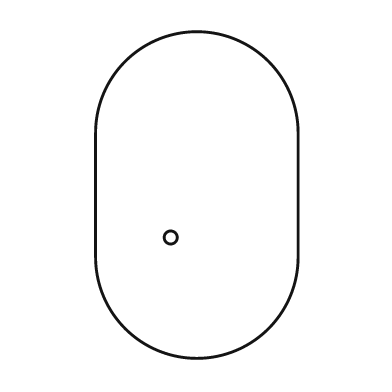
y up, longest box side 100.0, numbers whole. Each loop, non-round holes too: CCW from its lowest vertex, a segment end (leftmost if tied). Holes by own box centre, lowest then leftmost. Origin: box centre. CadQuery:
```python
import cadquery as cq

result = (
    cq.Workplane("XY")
    .moveTo(-31.0, -19.0)
    .threePointArc((0.0, -50.0), (31.0, -19.0))
    .lineTo(31.0, 19.0)
    .threePointArc((0.0, 50.0), (-31.0, 19.0))
    .close()
    .moveTo(-8.0, -13.0)
    .circle(2.0)
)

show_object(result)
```